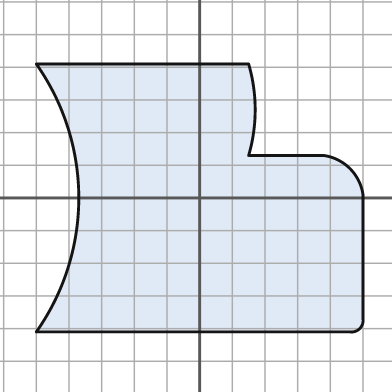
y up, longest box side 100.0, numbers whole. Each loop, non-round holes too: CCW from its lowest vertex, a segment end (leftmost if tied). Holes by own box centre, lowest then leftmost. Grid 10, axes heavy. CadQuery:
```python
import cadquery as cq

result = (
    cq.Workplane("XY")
    .moveTo(-50.0, -41.0)
    .lineTo(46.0, -41.0)
    .threePointArc((49.0, -40.0), (50.0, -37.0))
    .lineTo(50.0, 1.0)
    .threePointArc((46.0, 9.0), (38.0, 13.0))
    .lineTo(15.0, 13.0)
    .threePointArc((17.0, 27.0), (15.0, 41.0))
    .lineTo(-50.0, 41.0)
    .threePointArc((-37.0, 0.0), (-50.0, -41.0))
    .close()
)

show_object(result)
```